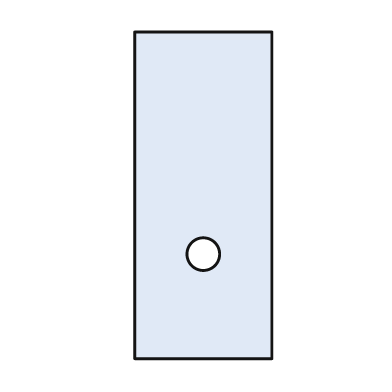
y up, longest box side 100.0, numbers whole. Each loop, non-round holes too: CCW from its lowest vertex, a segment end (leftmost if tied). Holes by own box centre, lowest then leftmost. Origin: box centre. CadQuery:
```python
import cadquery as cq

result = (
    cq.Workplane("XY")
    .moveTo(-21.0, -50.0)
    .lineTo(21.0, -50.0)
    .lineTo(21.0, 50.0)
    .lineTo(-21.0, 50.0)
    .close()
    .moveTo(0.0, -18.0)
    .circle(5.0)
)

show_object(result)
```